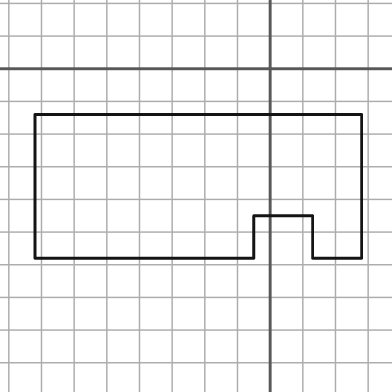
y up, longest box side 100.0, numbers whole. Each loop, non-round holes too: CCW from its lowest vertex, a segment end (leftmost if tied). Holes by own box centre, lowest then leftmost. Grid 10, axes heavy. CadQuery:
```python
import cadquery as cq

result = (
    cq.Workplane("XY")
    .moveTo(-72.0, -58.0)
    .lineTo(-5.0, -58.0)
    .lineTo(-5.0, -45.0)
    .lineTo(13.0, -45.0)
    .lineTo(13.0, -58.0)
    .lineTo(28.0, -58.0)
    .lineTo(28.0, -14.0)
    .lineTo(-72.0, -14.0)
    .close()
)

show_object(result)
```